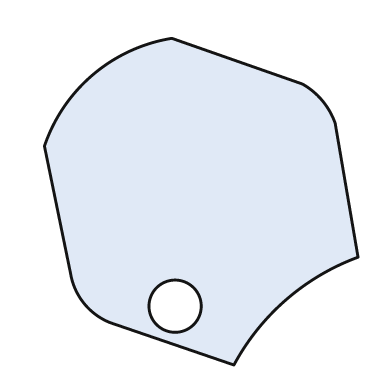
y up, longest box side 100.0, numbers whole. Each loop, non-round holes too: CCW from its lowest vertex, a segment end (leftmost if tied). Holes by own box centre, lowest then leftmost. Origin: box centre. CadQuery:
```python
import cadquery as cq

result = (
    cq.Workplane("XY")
    .moveTo(10.0, -50.0)
    .threePointArc((26.0, -30.0), (48.0, -17.0))
    .lineTo(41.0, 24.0)
    .threePointArc((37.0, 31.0), (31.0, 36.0))
    .lineTo(-9.0, 50.0)
    .threePointArc((-33.0, 39.0), (-48.0, 17.0))
    .lineTo(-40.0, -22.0)
    .threePointArc((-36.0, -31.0), (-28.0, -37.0))
    .close()
    .moveTo(-8.0, -32.0)
    .circle(8.0)
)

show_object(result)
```